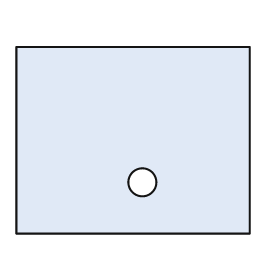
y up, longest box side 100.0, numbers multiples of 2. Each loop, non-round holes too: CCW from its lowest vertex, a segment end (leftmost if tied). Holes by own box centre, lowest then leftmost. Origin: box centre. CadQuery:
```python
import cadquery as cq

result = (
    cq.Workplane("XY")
    .moveTo(-50.0, -40.0)
    .lineTo(50.0, -40.0)
    .lineTo(50.0, 40.0)
    .lineTo(-50.0, 40.0)
    .close()
    .moveTo(4.0, -18.0)
    .circle(6.0)
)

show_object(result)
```